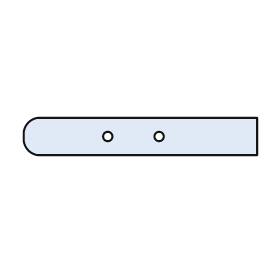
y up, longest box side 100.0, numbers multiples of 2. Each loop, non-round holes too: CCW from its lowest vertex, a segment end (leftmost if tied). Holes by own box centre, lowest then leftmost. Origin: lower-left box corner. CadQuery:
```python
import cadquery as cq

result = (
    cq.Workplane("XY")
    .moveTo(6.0, 0.0)
    .lineTo(100.0, 0.0)
    .lineTo(100.0, 16.0)
    .lineTo(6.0, 16.0)
    .threePointArc((2.0, 14.0), (0.0, 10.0))
    .lineTo(0.0, 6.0)
    .threePointArc((2.0, 2.0), (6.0, 0.0))
    .close()
    .moveTo(36.0, 8.0)
    .circle(2.0)
    .moveTo(58.0, 8.0)
    .circle(2.0)
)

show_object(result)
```